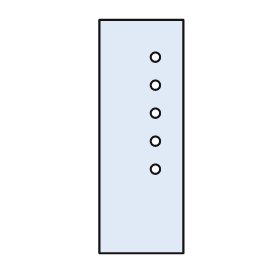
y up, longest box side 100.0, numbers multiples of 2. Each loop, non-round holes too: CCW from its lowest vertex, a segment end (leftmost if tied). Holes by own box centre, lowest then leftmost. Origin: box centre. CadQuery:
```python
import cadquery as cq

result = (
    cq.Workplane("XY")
    .moveTo(-18.0, -50.0)
    .lineTo(18.0, -50.0)
    .lineTo(18.0, 50.0)
    .lineTo(-18.0, 50.0)
    .close()
    .moveTo(6.0, -14.0)
    .circle(2.0)
    .moveTo(6.0, -2.0)
    .circle(2.0)
    .moveTo(6.0, 10.0)
    .circle(2.0)
    .moveTo(6.0, 22.0)
    .circle(2.0)
    .moveTo(6.0, 34.0)
    .circle(2.0)
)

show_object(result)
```